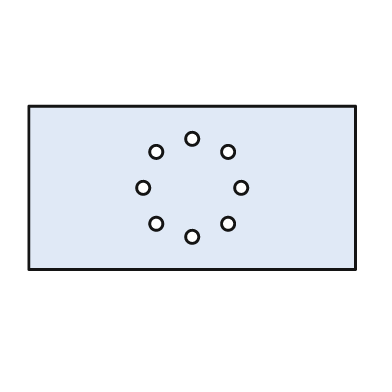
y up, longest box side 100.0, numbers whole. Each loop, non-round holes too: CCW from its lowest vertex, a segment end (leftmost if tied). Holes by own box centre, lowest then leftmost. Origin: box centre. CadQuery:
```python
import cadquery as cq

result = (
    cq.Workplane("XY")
    .moveTo(-50.0, -25.0)
    .lineTo(50.0, -25.0)
    .lineTo(50.0, 25.0)
    .lineTo(-50.0, 25.0)
    .close()
    .moveTo(0.0, -15.0)
    .circle(2.0)
    .moveTo(-11.0, -11.0)
    .circle(2.0)
    .moveTo(11.0, -11.0)
    .circle(2.0)
    .moveTo(-15.0, 0.0)
    .circle(2.0)
    .moveTo(15.0, 0.0)
    .circle(2.0)
    .moveTo(-11.0, 11.0)
    .circle(2.0)
    .moveTo(11.0, 11.0)
    .circle(2.0)
    .moveTo(0.0, 15.0)
    .circle(2.0)
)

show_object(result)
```